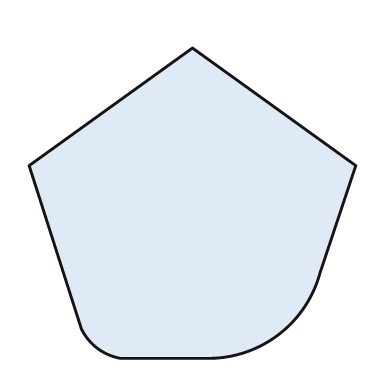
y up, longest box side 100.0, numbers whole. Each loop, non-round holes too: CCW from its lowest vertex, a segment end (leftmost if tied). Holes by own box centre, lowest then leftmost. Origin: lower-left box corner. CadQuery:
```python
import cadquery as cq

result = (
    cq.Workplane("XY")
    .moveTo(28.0, 0.0)
    .lineTo(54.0, 0.0)
    .threePointArc((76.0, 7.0), (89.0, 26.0))
    .lineTo(100.0, 59.0)
    .lineTo(50.0, 95.0)
    .lineTo(0.0, 59.0)
    .lineTo(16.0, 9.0)
    .threePointArc((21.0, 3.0), (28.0, 0.0))
    .close()
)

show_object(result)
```